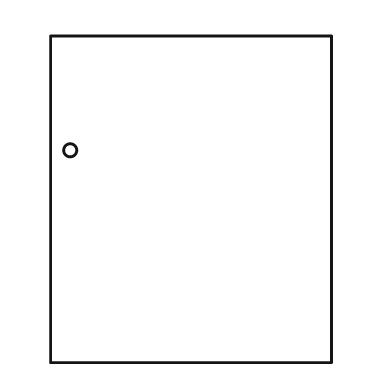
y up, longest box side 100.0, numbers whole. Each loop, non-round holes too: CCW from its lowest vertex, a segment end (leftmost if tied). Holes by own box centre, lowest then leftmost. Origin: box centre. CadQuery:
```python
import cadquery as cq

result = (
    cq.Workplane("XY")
    .moveTo(-43.0, -50.0)
    .lineTo(43.0, -50.0)
    .lineTo(43.0, 50.0)
    .lineTo(-43.0, 50.0)
    .close()
    .moveTo(-37.0, 15.0)
    .circle(2.0)
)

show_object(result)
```